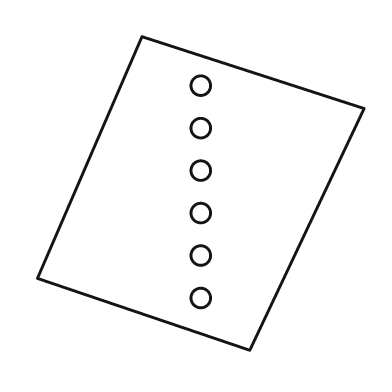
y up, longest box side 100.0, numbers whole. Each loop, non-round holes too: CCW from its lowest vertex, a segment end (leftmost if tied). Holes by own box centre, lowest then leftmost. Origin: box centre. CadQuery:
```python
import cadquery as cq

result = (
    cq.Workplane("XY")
    .moveTo(15.0, -48.0)
    .lineTo(50.0, 26.0)
    .lineTo(-18.0, 48.0)
    .lineTo(-50.0, -26.0)
    .close()
    .moveTo(0.0, -32.0)
    .circle(3.0)
    .moveTo(0.0, -19.0)
    .circle(3.0)
    .moveTo(0.0, -6.0)
    .circle(3.0)
    .moveTo(0.0, 7.0)
    .circle(3.0)
    .moveTo(0.0, 20.0)
    .circle(3.0)
    .moveTo(0.0, 33.0)
    .circle(3.0)
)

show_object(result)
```